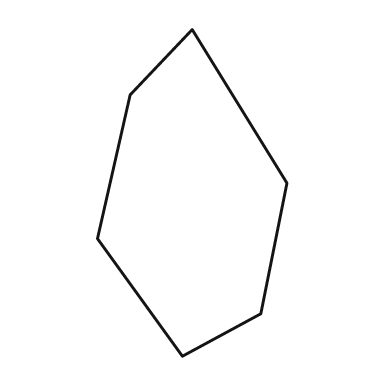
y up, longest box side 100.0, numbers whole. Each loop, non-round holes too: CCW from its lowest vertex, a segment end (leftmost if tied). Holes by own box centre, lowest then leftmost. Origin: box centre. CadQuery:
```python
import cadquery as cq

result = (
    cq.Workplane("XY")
    .moveTo(-3.0, -50.0)
    .lineTo(21.0, -37.0)
    .lineTo(29.0, 3.0)
    .lineTo(0.0, 50.0)
    .lineTo(-19.0, 30.0)
    .lineTo(-29.0, -14.0)
    .close()
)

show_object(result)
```